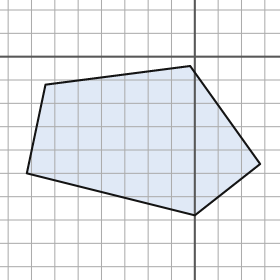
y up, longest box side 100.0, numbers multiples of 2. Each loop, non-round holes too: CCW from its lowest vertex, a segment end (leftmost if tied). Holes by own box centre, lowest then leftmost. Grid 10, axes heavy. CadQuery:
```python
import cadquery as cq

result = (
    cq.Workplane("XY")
    .moveTo(0.0, -68.0)
    .lineTo(28.0, -46.0)
    .lineTo(-2.0, -4.0)
    .lineTo(-64.0, -12.0)
    .lineTo(-72.0, -50.0)
    .close()
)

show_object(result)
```